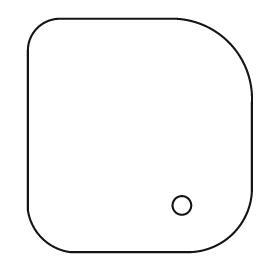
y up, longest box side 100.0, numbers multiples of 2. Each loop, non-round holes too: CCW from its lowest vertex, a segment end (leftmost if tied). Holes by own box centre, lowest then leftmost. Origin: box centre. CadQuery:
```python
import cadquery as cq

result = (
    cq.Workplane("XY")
    .moveTo(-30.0, -50.0)
    .lineTo(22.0, -50.0)
    .threePointArc((40.0, -42.0), (48.0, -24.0))
    .lineTo(48.0, 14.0)
    .threePointArc((38.0, 40.0), (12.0, 50.0))
    .lineTo(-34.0, 50.0)
    .threePointArc((-44.0, 46.0), (-48.0, 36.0))
    .lineTo(-48.0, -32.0)
    .threePointArc((-42.0, -44.0), (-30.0, -50.0))
    .close()
    .moveTo(18.0, -30.0)
    .circle(4.0)
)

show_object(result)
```